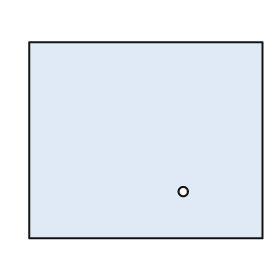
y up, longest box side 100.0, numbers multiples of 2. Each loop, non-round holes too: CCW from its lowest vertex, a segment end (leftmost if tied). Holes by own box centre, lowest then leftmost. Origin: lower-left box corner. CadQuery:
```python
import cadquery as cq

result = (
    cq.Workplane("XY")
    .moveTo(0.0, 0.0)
    .lineTo(100.0, 0.0)
    .lineTo(100.0, 84.0)
    .lineTo(0.0, 84.0)
    .close()
    .moveTo(66.0, 20.0)
    .circle(2.0)
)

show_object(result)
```